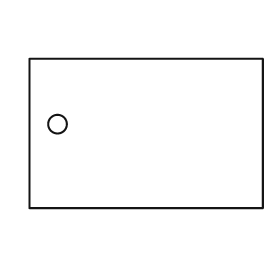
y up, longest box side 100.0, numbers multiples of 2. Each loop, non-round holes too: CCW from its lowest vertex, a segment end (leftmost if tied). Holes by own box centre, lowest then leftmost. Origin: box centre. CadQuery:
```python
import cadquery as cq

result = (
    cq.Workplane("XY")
    .moveTo(-50.0, -32.0)
    .lineTo(50.0, -32.0)
    .lineTo(50.0, 32.0)
    .lineTo(-50.0, 32.0)
    .close()
    .moveTo(-38.0, 4.0)
    .circle(4.0)
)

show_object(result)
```